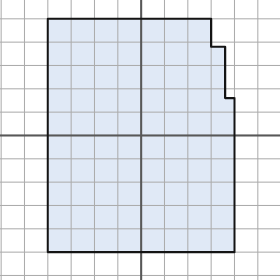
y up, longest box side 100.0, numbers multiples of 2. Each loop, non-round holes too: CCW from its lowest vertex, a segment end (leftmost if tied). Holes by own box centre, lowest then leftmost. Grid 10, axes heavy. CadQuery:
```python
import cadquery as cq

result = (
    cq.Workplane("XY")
    .moveTo(-40.0, -50.0)
    .lineTo(40.0, -50.0)
    .lineTo(40.0, 16.0)
    .lineTo(36.0, 16.0)
    .lineTo(36.0, 38.0)
    .lineTo(30.0, 38.0)
    .lineTo(30.0, 50.0)
    .lineTo(-40.0, 50.0)
    .close()
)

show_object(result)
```